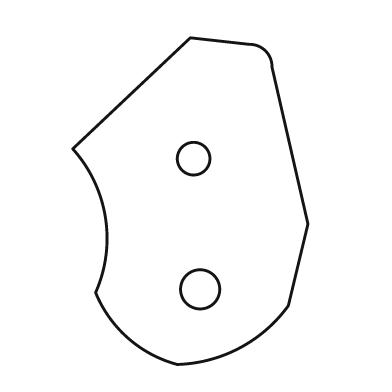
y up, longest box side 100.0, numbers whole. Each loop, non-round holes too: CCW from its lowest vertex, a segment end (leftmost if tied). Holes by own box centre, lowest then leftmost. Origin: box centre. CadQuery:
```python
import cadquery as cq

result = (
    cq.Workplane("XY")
    .moveTo(-4.0, -50.0)
    .threePointArc((15.0, -45.0), (30.0, -32.0))
    .lineTo(36.0, -7.0)
    .lineTo(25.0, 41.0)
    .threePointArc((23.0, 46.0), (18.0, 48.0))
    .lineTo(0.0, 50.0)
    .lineTo(-36.0, 16.0)
    .threePointArc((-26.0, -5.0), (-29.0, -28.0))
    .threePointArc((-19.0, -42.0), (-4.0, -50.0))
    .close()
    .moveTo(3.0, -27.0)
    .circle(6.0)
    .moveTo(1.0, 13.0)
    .circle(5.0)
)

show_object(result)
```